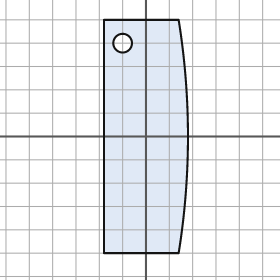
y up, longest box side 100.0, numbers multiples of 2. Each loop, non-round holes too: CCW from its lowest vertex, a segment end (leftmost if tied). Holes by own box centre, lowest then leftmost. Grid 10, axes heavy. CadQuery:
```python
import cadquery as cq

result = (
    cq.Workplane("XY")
    .moveTo(-18.0, -50.0)
    .lineTo(14.0, -50.0)
    .threePointArc((18.0, 0.0), (14.0, 50.0))
    .lineTo(-18.0, 50.0)
    .close()
    .moveTo(-10.0, 40.0)
    .circle(4.0)
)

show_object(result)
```